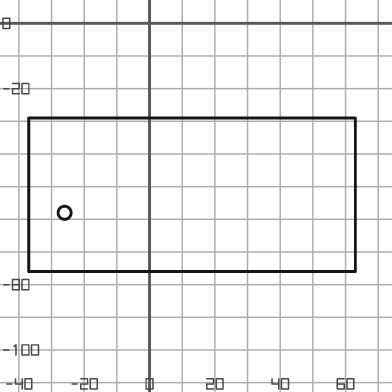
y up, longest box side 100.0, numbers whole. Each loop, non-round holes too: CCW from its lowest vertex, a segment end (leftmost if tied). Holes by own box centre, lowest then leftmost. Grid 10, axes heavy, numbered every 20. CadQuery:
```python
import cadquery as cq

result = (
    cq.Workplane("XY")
    .moveTo(-37.0, -76.0)
    .lineTo(63.0, -76.0)
    .lineTo(63.0, -29.0)
    .lineTo(-37.0, -29.0)
    .close()
    .moveTo(-26.0, -58.0)
    .circle(2.0)
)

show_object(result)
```